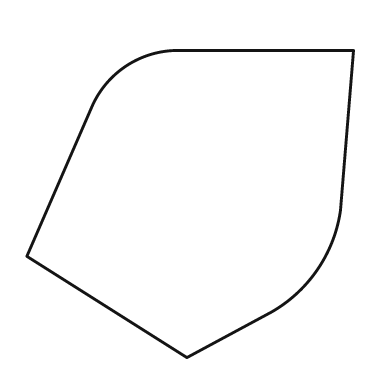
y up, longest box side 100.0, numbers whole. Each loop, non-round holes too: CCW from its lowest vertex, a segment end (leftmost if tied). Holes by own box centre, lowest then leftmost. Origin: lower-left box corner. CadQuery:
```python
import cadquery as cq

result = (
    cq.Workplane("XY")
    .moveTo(49.0, 0.0)
    .lineTo(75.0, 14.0)
    .threePointArc((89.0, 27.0), (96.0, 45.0))
    .lineTo(100.0, 94.0)
    .lineTo(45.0, 94.0)
    .threePointArc((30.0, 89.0), (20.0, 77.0))
    .lineTo(0.0, 31.0)
    .close()
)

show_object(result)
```